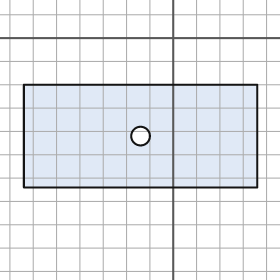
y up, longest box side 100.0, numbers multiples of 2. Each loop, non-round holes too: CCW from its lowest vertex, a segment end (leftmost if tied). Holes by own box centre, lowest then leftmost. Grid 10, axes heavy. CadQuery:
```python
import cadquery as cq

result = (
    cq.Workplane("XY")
    .moveTo(-64.0, -64.0)
    .lineTo(36.0, -64.0)
    .lineTo(36.0, -20.0)
    .lineTo(-64.0, -20.0)
    .close()
    .moveTo(-14.0, -42.0)
    .circle(4.0)
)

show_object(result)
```